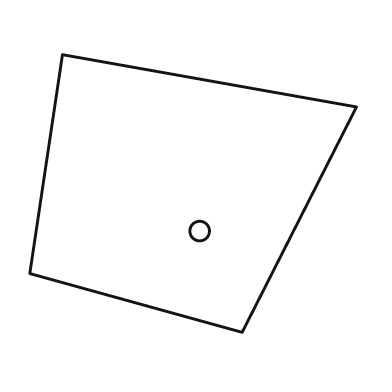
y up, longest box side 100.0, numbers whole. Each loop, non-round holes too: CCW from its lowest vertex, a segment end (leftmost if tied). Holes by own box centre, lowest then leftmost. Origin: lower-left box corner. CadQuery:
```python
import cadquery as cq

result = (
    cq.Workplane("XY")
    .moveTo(65.0, 0.0)
    .lineTo(100.0, 69.0)
    .lineTo(10.0, 85.0)
    .lineTo(0.0, 18.0)
    .close()
    .moveTo(52.0, 31.0)
    .circle(3.0)
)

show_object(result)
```